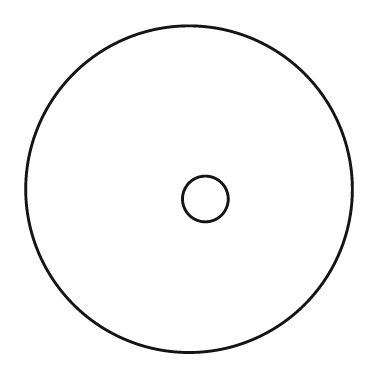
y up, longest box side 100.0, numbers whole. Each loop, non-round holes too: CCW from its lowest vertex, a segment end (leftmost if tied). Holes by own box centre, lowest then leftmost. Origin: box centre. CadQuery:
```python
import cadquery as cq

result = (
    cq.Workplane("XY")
    .moveTo(0.0, 0.0)
    .circle(50.0)
    .moveTo(5.0, -3.0)
    .circle(7.0)
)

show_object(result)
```